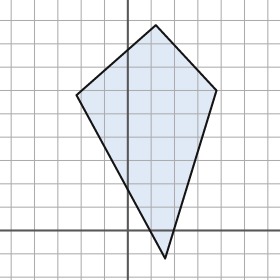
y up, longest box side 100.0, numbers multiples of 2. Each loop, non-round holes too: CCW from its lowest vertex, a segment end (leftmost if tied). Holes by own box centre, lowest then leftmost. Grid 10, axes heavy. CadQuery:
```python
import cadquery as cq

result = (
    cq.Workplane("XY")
    .moveTo(16.0, -12.0)
    .lineTo(38.0, 60.0)
    .lineTo(12.0, 88.0)
    .lineTo(-22.0, 58.0)
    .close()
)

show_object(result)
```